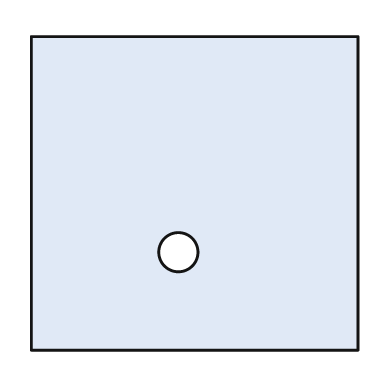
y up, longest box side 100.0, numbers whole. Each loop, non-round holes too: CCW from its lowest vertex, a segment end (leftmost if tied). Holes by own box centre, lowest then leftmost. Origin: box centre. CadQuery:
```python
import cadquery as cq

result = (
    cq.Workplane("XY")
    .moveTo(-50.0, -48.0)
    .lineTo(50.0, -48.0)
    .lineTo(50.0, 48.0)
    .lineTo(-50.0, 48.0)
    .close()
    .moveTo(-5.0, -18.0)
    .circle(6.0)
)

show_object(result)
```